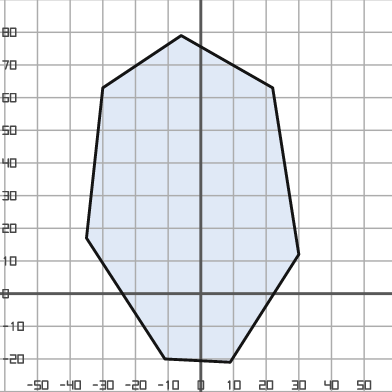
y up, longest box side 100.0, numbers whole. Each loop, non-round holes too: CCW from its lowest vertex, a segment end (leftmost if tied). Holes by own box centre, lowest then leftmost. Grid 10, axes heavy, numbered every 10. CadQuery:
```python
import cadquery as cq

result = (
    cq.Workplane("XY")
    .moveTo(9.0, -21.0)
    .lineTo(30.0, 12.0)
    .lineTo(22.0, 63.0)
    .lineTo(-6.0, 79.0)
    .lineTo(-30.0, 63.0)
    .lineTo(-35.0, 17.0)
    .lineTo(-11.0, -20.0)
    .close()
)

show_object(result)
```